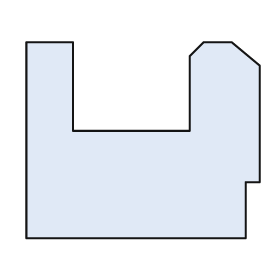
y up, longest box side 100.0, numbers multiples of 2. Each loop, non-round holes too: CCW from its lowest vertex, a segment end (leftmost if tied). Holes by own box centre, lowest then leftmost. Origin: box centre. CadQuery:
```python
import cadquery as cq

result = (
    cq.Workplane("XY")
    .moveTo(-50.0, -42.0)
    .lineTo(44.0, -42.0)
    .lineTo(44.0, -18.0)
    .lineTo(50.0, -18.0)
    .lineTo(50.0, 32.0)
    .lineTo(38.0, 42.0)
    .lineTo(26.0, 42.0)
    .lineTo(20.0, 36.0)
    .lineTo(20.0, 4.0)
    .lineTo(-30.0, 4.0)
    .lineTo(-30.0, 42.0)
    .lineTo(-50.0, 42.0)
    .close()
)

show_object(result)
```